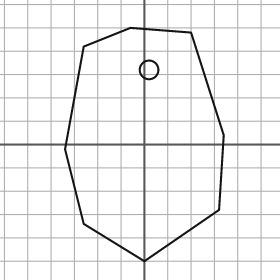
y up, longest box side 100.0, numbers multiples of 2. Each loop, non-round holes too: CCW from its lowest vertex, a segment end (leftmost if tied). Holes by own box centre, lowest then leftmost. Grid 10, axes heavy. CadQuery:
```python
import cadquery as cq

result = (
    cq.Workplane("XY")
    .moveTo(0.0, -50.0)
    .lineTo(32.0, -28.0)
    .lineTo(34.0, 4.0)
    .lineTo(20.0, 48.0)
    .lineTo(-6.0, 50.0)
    .lineTo(-26.0, 42.0)
    .lineTo(-34.0, -2.0)
    .lineTo(-26.0, -34.0)
    .close()
    .moveTo(2.0, 32.0)
    .circle(4.0)
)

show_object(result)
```